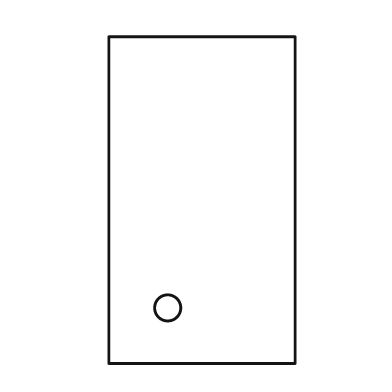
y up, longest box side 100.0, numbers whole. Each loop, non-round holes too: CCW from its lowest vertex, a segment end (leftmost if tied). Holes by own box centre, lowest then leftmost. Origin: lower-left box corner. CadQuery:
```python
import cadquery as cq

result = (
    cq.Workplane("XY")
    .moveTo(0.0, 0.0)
    .lineTo(57.0, 0.0)
    .lineTo(57.0, 100.0)
    .lineTo(0.0, 100.0)
    .close()
    .moveTo(18.0, 17.0)
    .circle(4.0)
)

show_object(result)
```